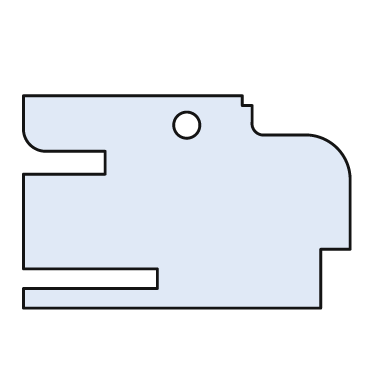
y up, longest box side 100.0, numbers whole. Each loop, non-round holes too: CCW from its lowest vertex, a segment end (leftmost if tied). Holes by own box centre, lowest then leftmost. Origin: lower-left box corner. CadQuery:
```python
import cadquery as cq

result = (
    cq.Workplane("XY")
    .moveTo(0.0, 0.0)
    .lineTo(91.0, 0.0)
    .lineTo(91.0, 18.0)
    .lineTo(100.0, 18.0)
    .lineTo(100.0, 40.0)
    .threePointArc((96.0, 49.0), (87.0, 53.0))
    .lineTo(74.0, 53.0)
    .threePointArc((71.0, 54.0), (70.0, 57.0))
    .lineTo(70.0, 62.0)
    .lineTo(67.0, 62.0)
    .lineTo(67.0, 65.0)
    .lineTo(0.0, 65.0)
    .lineTo(0.0, 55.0)
    .threePointArc((2.0, 50.0), (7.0, 48.0))
    .lineTo(25.0, 48.0)
    .lineTo(25.0, 41.0)
    .lineTo(0.0, 41.0)
    .lineTo(0.0, 12.0)
    .lineTo(41.0, 12.0)
    .lineTo(41.0, 6.0)
    .lineTo(0.0, 6.0)
    .close()
    .moveTo(50.0, 56.0)
    .circle(4.0)
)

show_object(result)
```